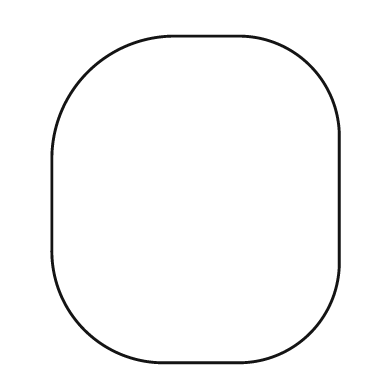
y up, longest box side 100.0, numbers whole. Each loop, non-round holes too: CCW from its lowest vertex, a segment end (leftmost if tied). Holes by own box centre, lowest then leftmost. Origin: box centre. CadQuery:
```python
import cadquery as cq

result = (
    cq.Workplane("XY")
    .moveTo(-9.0, -50.0)
    .lineTo(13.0, -50.0)
    .threePointArc((35.0, -41.0), (44.0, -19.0))
    .lineTo(44.0, 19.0)
    .threePointArc((35.0, 41.0), (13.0, 50.0))
    .lineTo(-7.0, 50.0)
    .threePointArc((-33.0, 39.0), (-44.0, 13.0))
    .lineTo(-44.0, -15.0)
    .threePointArc((-34.0, -40.0), (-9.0, -50.0))
    .close()
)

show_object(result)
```